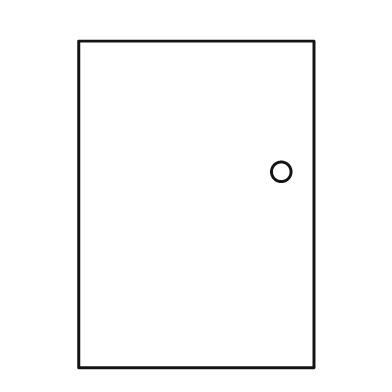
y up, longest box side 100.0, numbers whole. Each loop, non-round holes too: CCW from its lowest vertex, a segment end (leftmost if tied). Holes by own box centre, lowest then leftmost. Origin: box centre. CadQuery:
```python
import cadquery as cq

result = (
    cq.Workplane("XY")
    .moveTo(-36.0, -50.0)
    .lineTo(36.0, -50.0)
    .lineTo(36.0, 50.0)
    .lineTo(-36.0, 50.0)
    .close()
    .moveTo(26.0, 10.0)
    .circle(3.0)
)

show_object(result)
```